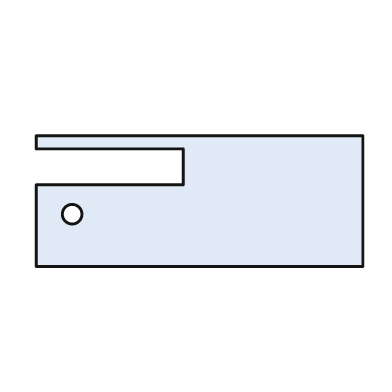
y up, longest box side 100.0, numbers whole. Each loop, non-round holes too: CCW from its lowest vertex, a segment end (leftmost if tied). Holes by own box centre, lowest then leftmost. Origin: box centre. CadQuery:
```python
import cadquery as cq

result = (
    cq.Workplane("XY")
    .moveTo(-50.0, -20.0)
    .lineTo(50.0, -20.0)
    .lineTo(50.0, 20.0)
    .lineTo(-50.0, 20.0)
    .lineTo(-50.0, 16.0)
    .lineTo(-5.0, 16.0)
    .lineTo(-5.0, 5.0)
    .lineTo(-50.0, 5.0)
    .close()
    .moveTo(-39.0, -4.0)
    .circle(3.0)
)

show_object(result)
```